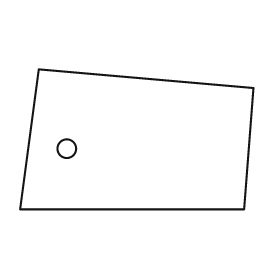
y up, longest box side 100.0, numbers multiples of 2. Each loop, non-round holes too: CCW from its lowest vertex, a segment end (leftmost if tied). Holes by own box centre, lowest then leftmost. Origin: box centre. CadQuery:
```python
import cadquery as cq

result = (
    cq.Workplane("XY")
    .moveTo(-50.0, -30.0)
    .lineTo(46.0, -30.0)
    .lineTo(50.0, 22.0)
    .lineTo(-42.0, 30.0)
    .close()
    .moveTo(-30.0, -4.0)
    .circle(4.0)
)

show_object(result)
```